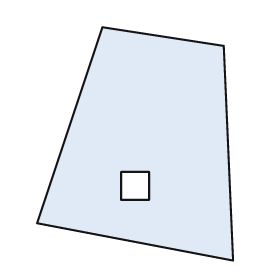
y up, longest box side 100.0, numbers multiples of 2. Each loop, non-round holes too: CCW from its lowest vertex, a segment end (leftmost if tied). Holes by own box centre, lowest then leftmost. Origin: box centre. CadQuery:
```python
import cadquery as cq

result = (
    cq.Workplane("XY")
    .moveTo(42.0, -50.0)
    .lineTo(38.0, 42.0)
    .lineTo(-14.0, 50.0)
    .lineTo(-42.0, -34.0)
    .close()
    .moveTo(-6.0, -24.0)
    .lineTo(6.0, -24.0)
    .lineTo(6.0, -12.0)
    .lineTo(-6.0, -12.0)
    .close()
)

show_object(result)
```